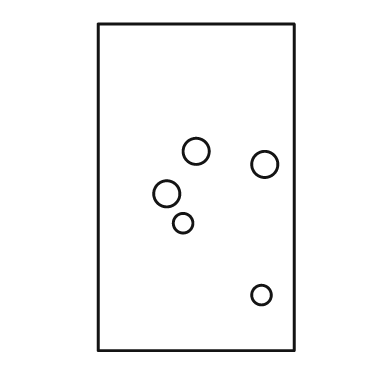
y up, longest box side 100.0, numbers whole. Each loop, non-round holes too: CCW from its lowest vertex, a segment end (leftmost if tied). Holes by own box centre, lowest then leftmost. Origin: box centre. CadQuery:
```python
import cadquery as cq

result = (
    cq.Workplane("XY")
    .moveTo(-30.0, -50.0)
    .lineTo(30.0, -50.0)
    .lineTo(30.0, 50.0)
    .lineTo(-30.0, 50.0)
    .close()
    .moveTo(20.0, -33.0)
    .circle(3.0)
    .moveTo(-4.0, -11.0)
    .circle(3.0)
    .moveTo(-9.0, -2.0)
    .circle(4.0)
    .moveTo(21.0, 7.0)
    .circle(4.0)
    .moveTo(0.0, 11.0)
    .circle(4.0)
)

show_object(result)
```